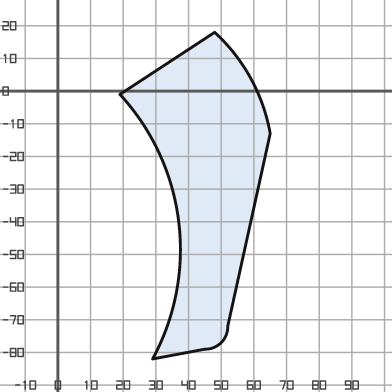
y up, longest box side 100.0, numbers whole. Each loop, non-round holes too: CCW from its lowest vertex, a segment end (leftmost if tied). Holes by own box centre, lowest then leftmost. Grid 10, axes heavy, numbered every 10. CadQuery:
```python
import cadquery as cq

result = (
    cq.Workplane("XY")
    .moveTo(29.0, -82.0)
    .lineTo(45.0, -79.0)
    .threePointArc((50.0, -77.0), (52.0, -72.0))
    .lineTo(65.0, -13.0)
    .threePointArc((59.0, 4.0), (48.0, 18.0))
    .lineTo(19.0, -1.0)
    .threePointArc((37.0, -40.0), (29.0, -82.0))
    .close()
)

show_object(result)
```